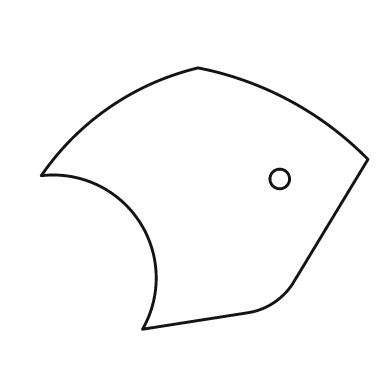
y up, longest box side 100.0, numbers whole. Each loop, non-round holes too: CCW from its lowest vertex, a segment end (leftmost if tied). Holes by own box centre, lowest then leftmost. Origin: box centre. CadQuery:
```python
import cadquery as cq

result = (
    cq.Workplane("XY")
    .moveTo(-19.0, -40.0)
    .lineTo(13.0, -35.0)
    .threePointArc((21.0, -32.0), (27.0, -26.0))
    .lineTo(50.0, 12.0)
    .threePointArc((26.0, 30.0), (-2.0, 40.0))
    .threePointArc((-29.0, 28.0), (-50.0, 7.0))
    .threePointArc((-20.0, -7.0), (-19.0, -40.0))
    .close()
    .moveTo(23.0, 6.0)
    .circle(3.0)
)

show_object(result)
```